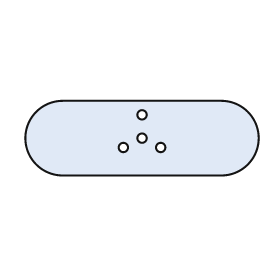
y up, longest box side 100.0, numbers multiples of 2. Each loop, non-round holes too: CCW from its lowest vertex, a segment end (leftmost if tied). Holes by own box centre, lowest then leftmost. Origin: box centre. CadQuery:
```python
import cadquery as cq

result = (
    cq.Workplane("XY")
    .moveTo(-34.0, -16.0)
    .lineTo(34.0, -16.0)
    .threePointArc((50.0, 0.0), (34.0, 16.0))
    .lineTo(-34.0, 16.0)
    .threePointArc((-50.0, 0.0), (-34.0, -16.0))
    .close()
    .moveTo(-8.0, -4.0)
    .circle(2.0)
    .moveTo(8.0, -4.0)
    .circle(2.0)
    .moveTo(0.0, 0.0)
    .circle(2.0)
    .moveTo(0.0, 10.0)
    .circle(2.0)
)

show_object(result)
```